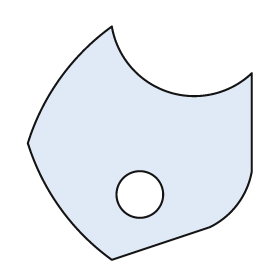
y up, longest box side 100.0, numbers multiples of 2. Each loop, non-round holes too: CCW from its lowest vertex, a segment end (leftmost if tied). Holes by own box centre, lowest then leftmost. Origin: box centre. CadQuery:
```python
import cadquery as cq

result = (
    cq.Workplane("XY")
    .moveTo(-12.0, -50.0)
    .lineTo(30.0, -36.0)
    .threePointArc((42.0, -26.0), (48.0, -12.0))
    .lineTo(48.0, 30.0)
    .threePointArc((12.0, 22.0), (-12.0, 50.0))
    .threePointArc((-34.0, 28.0), (-48.0, 0.0))
    .threePointArc((-34.0, -28.0), (-12.0, -50.0))
    .close()
    .moveTo(0.0, -22.0)
    .circle(10.0)
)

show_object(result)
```